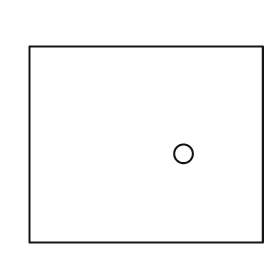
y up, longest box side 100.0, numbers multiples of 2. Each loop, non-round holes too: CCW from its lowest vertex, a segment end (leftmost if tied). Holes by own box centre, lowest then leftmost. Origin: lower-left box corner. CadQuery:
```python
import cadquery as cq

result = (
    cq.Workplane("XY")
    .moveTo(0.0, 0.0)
    .lineTo(100.0, 0.0)
    .lineTo(100.0, 84.0)
    .lineTo(0.0, 84.0)
    .close()
    .moveTo(66.0, 38.0)
    .circle(4.0)
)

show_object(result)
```